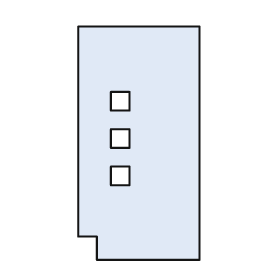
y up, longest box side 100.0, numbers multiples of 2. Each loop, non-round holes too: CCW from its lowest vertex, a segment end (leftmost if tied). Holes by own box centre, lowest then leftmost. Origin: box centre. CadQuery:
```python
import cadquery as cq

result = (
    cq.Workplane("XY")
    .moveTo(-18.0, -50.0)
    .lineTo(26.0, -50.0)
    .lineTo(26.0, 50.0)
    .lineTo(-26.0, 50.0)
    .lineTo(-26.0, -40.0)
    .lineTo(-18.0, -40.0)
    .close()
    .moveTo(-12.0, -18.0)
    .lineTo(-4.0, -18.0)
    .lineTo(-4.0, -10.0)
    .lineTo(-12.0, -10.0)
    .close()
    .moveTo(-12.0, -2.0)
    .lineTo(-4.0, -2.0)
    .lineTo(-4.0, 6.0)
    .lineTo(-12.0, 6.0)
    .close()
    .moveTo(-12.0, 14.0)
    .lineTo(-4.0, 14.0)
    .lineTo(-4.0, 22.0)
    .lineTo(-12.0, 22.0)
    .close()
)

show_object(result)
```